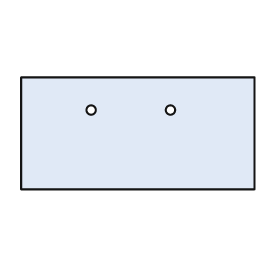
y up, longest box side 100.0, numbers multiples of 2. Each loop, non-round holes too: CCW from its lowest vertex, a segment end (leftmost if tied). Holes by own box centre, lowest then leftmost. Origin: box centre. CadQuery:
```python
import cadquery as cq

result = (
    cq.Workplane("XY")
    .moveTo(-50.0, -24.0)
    .lineTo(50.0, -24.0)
    .lineTo(50.0, 24.0)
    .lineTo(-50.0, 24.0)
    .close()
    .moveTo(-20.0, 10.0)
    .circle(2.0)
    .moveTo(14.0, 10.0)
    .circle(2.0)
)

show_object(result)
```